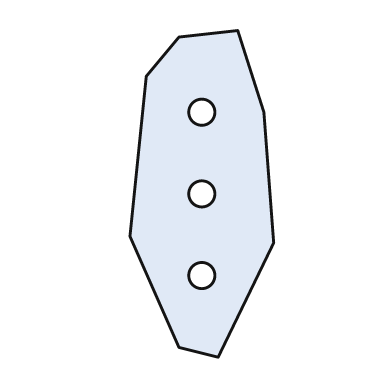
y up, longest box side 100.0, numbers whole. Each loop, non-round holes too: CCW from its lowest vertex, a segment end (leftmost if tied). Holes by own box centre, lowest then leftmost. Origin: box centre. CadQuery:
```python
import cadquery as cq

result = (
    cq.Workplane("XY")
    .moveTo(5.0, -50.0)
    .lineTo(22.0, -15.0)
    .lineTo(19.0, 25.0)
    .lineTo(11.0, 50.0)
    .lineTo(-7.0, 48.0)
    .lineTo(-17.0, 36.0)
    .lineTo(-22.0, -13.0)
    .lineTo(-7.0, -47.0)
    .close()
    .moveTo(0.0, -25.0)
    .circle(4.0)
    .moveTo(0.0, 0.0)
    .circle(4.0)
    .moveTo(0.0, 25.0)
    .circle(4.0)
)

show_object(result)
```